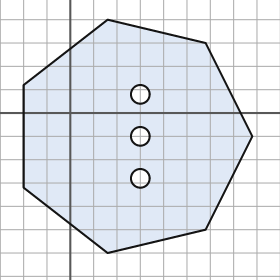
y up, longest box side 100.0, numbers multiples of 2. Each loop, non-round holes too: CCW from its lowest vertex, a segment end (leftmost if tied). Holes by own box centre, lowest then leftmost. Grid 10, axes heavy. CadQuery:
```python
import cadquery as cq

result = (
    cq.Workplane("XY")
    .moveTo(16.0, -60.0)
    .lineTo(58.0, -50.0)
    .lineTo(78.0, -10.0)
    .lineTo(58.0, 30.0)
    .lineTo(16.0, 40.0)
    .lineTo(-20.0, 12.0)
    .lineTo(-20.0, -32.0)
    .close()
    .moveTo(30.0, -28.0)
    .circle(4.0)
    .moveTo(30.0, -10.0)
    .circle(4.0)
    .moveTo(30.0, 8.0)
    .circle(4.0)
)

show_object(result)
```